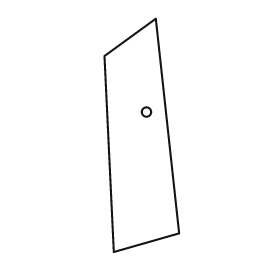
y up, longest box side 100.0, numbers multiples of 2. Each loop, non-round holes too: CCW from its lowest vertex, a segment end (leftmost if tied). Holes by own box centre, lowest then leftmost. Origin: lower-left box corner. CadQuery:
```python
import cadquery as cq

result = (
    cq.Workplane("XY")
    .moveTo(4.0, 0.0)
    .lineTo(32.0, 8.0)
    .lineTo(22.0, 100.0)
    .lineTo(0.0, 84.0)
    .close()
    .moveTo(18.0, 60.0)
    .circle(2.0)
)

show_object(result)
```